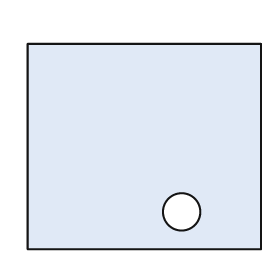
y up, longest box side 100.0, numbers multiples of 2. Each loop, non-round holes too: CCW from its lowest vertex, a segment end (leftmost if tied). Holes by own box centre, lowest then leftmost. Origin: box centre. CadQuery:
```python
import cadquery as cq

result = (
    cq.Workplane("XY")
    .moveTo(-50.0, -44.0)
    .lineTo(50.0, -44.0)
    .lineTo(50.0, 44.0)
    .lineTo(-50.0, 44.0)
    .close()
    .moveTo(16.0, -28.0)
    .circle(8.0)
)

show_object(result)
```